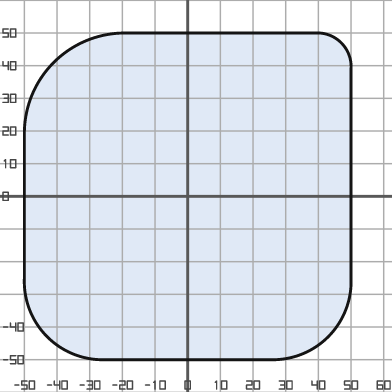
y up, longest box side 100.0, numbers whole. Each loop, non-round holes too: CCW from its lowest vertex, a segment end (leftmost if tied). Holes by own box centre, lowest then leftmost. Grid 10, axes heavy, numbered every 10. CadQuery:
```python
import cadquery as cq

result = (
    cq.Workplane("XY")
    .moveTo(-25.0, -50.0)
    .lineTo(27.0, -50.0)
    .threePointArc((43.0, -43.0), (50.0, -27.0))
    .lineTo(50.0, 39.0)
    .threePointArc((47.0, 47.0), (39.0, 50.0))
    .lineTo(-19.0, 50.0)
    .threePointArc((-41.0, 41.0), (-50.0, 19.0))
    .lineTo(-50.0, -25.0)
    .threePointArc((-43.0, -43.0), (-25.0, -50.0))
    .close()
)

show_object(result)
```